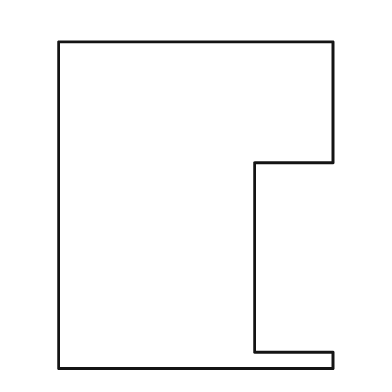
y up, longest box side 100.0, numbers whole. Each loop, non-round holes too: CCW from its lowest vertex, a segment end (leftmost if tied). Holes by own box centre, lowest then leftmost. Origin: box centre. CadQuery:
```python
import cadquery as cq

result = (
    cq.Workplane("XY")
    .moveTo(-42.0, -50.0)
    .lineTo(42.0, -50.0)
    .lineTo(42.0, -45.0)
    .lineTo(18.0, -45.0)
    .lineTo(18.0, 13.0)
    .lineTo(42.0, 13.0)
    .lineTo(42.0, 50.0)
    .lineTo(-42.0, 50.0)
    .close()
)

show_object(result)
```